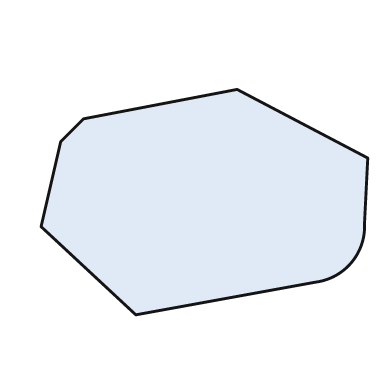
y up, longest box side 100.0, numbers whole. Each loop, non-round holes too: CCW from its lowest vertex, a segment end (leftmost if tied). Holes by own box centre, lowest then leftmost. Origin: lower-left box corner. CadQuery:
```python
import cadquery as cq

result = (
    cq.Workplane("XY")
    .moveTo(29.0, 0.0)
    .lineTo(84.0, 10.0)
    .threePointArc((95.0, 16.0), (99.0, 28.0))
    .lineTo(100.0, 48.0)
    .lineTo(60.0, 69.0)
    .lineTo(13.0, 60.0)
    .lineTo(6.0, 53.0)
    .lineTo(0.0, 27.0)
    .close()
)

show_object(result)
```